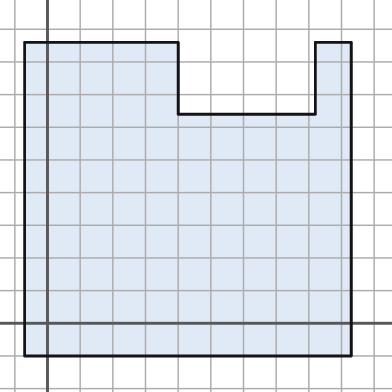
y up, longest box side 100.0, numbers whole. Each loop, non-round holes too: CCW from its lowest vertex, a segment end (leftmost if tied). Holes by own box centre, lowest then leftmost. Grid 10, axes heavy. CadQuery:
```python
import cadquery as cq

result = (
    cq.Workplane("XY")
    .moveTo(-7.0, -10.0)
    .lineTo(93.0, -10.0)
    .lineTo(93.0, 86.0)
    .lineTo(82.0, 86.0)
    .lineTo(82.0, 64.0)
    .lineTo(40.0, 64.0)
    .lineTo(40.0, 86.0)
    .lineTo(-7.0, 86.0)
    .close()
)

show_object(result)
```